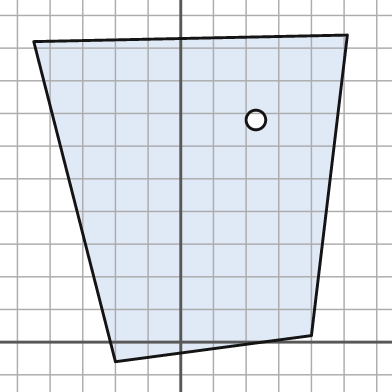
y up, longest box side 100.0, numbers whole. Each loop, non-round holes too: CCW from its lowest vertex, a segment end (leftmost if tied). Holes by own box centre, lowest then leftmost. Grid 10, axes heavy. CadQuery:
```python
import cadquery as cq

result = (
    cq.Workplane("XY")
    .moveTo(-20.0, -6.0)
    .lineTo(40.0, 2.0)
    .lineTo(51.0, 94.0)
    .lineTo(-45.0, 92.0)
    .close()
    .moveTo(23.0, 68.0)
    .circle(3.0)
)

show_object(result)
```